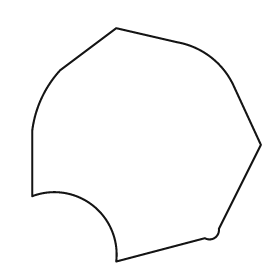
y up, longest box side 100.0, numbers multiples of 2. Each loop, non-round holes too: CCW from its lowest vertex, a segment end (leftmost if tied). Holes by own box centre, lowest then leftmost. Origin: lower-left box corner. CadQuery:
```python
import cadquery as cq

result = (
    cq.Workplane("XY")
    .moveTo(36.0, 0.0)
    .lineTo(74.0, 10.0)
    .threePointArc((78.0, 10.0), (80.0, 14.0))
    .lineTo(98.0, 50.0)
    .lineTo(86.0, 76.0)
    .threePointArc((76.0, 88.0), (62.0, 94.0))
    .lineTo(36.0, 100.0)
    .lineTo(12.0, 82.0)
    .threePointArc((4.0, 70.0), (0.0, 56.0))
    .lineTo(0.0, 28.0)
    .threePointArc((26.0, 24.0), (36.0, 0.0))
    .close()
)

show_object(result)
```